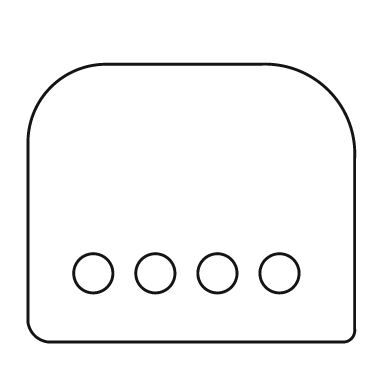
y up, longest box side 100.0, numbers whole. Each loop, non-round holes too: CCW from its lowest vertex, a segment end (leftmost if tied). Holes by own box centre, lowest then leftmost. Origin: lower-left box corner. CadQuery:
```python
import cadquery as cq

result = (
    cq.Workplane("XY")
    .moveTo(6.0, 0.0)
    .lineTo(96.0, 0.0)
    .threePointArc((99.0, 1.0), (100.0, 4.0))
    .lineTo(100.0, 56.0)
    .threePointArc((92.0, 77.0), (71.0, 85.0))
    .lineTo(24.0, 85.0)
    .threePointArc((7.0, 78.0), (0.0, 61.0))
    .lineTo(0.0, 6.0)
    .threePointArc((2.0, 2.0), (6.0, 0.0))
    .close()
    .moveTo(20.0, 21.0)
    .circle(6.0)
    .moveTo(39.0, 21.0)
    .circle(6.0)
    .moveTo(58.0, 21.0)
    .circle(6.0)
    .moveTo(77.0, 21.0)
    .circle(6.0)
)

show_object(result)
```